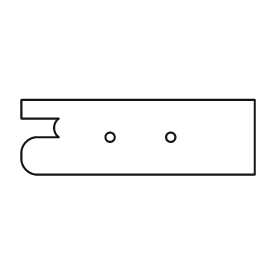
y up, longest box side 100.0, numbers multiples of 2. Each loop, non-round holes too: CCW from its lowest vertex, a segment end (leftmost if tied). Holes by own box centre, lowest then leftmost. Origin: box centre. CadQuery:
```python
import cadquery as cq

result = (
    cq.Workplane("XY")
    .moveTo(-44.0, -16.0)
    .lineTo(50.0, -16.0)
    .lineTo(50.0, 16.0)
    .lineTo(-50.0, 16.0)
    .lineTo(-50.0, 8.0)
    .lineTo(-34.0, 8.0)
    .threePointArc((-36.0, 4.0), (-34.0, 0.0))
    .lineTo(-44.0, 0.0)
    .threePointArc((-48.0, -2.0), (-50.0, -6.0))
    .lineTo(-50.0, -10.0)
    .threePointArc((-48.0, -14.0), (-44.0, -16.0))
    .close()
    .moveTo(-12.0, 0.0)
    .circle(2.0)
    .moveTo(14.0, 0.0)
    .circle(2.0)
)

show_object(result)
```